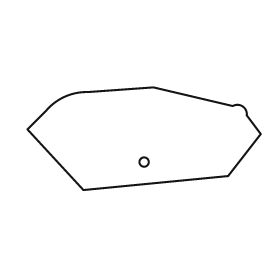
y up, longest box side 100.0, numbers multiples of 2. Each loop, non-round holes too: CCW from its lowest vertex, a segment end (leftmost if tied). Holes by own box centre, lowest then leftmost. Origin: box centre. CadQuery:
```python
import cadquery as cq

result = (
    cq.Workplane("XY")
    .moveTo(-26.0, -22.0)
    .lineTo(36.0, -16.0)
    .lineTo(50.0, 2.0)
    .lineTo(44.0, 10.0)
    .threePointArc((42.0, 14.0), (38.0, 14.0))
    .lineTo(4.0, 22.0)
    .lineTo(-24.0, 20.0)
    .threePointArc((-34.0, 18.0), (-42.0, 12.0))
    .lineTo(-50.0, 4.0)
    .close()
    .moveTo(0.0, -10.0)
    .circle(2.0)
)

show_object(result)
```